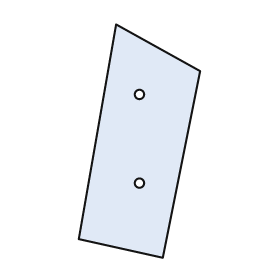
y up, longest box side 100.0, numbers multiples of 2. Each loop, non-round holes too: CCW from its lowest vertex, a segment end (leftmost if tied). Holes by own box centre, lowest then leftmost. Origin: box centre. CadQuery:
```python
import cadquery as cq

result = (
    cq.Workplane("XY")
    .moveTo(10.0, -50.0)
    .lineTo(26.0, 30.0)
    .lineTo(-10.0, 50.0)
    .lineTo(-26.0, -42.0)
    .close()
    .moveTo(0.0, -18.0)
    .circle(2.0)
    .moveTo(0.0, 20.0)
    .circle(2.0)
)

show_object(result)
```